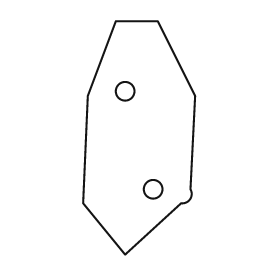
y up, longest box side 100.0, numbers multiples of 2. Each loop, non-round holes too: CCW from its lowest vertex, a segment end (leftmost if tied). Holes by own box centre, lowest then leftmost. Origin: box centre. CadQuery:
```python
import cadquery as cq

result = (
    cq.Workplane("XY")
    .moveTo(-6.0, -50.0)
    .lineTo(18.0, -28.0)
    .threePointArc((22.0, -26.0), (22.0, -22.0))
    .lineTo(24.0, 18.0)
    .lineTo(8.0, 50.0)
    .lineTo(-10.0, 50.0)
    .lineTo(-22.0, 18.0)
    .lineTo(-24.0, -28.0)
    .close()
    .moveTo(6.0, -22.0)
    .circle(4.0)
    .moveTo(-6.0, 20.0)
    .circle(4.0)
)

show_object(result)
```